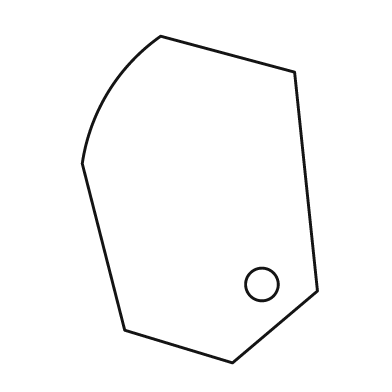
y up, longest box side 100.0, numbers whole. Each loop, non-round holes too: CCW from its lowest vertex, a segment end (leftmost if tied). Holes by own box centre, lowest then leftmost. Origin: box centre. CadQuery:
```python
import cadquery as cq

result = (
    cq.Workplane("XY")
    .moveTo(10.0, -50.0)
    .lineTo(36.0, -28.0)
    .lineTo(29.0, 39.0)
    .lineTo(-12.0, 50.0)
    .threePointArc((-28.0, 33.0), (-36.0, 11.0))
    .lineTo(-23.0, -40.0)
    .close()
    .moveTo(19.0, -26.0)
    .circle(5.0)
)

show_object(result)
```